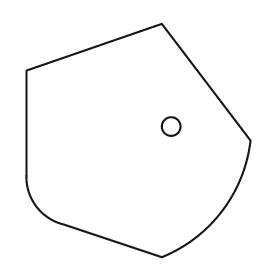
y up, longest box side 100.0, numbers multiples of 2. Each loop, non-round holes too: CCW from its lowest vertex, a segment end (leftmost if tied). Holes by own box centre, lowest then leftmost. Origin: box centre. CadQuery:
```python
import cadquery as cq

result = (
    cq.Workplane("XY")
    .moveTo(10.0, -50.0)
    .threePointArc((36.0, -30.0), (48.0, 0.0))
    .lineTo(10.0, 50.0)
    .lineTo(-48.0, 30.0)
    .lineTo(-48.0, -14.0)
    .threePointArc((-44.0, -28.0), (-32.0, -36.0))
    .close()
    .moveTo(14.0, 6.0)
    .circle(4.0)
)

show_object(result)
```